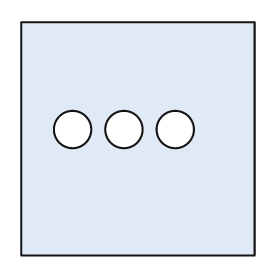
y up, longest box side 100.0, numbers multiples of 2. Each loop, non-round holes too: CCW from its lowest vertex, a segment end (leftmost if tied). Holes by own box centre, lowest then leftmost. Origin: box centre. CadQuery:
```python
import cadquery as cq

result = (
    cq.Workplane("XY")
    .moveTo(-50.0, -50.0)
    .lineTo(50.0, -50.0)
    .lineTo(50.0, 50.0)
    .lineTo(-50.0, 50.0)
    .close()
    .moveTo(-28.0, 4.0)
    .circle(8.0)
    .moveTo(-6.0, 4.0)
    .circle(8.0)
    .moveTo(16.0, 4.0)
    .circle(8.0)
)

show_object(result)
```